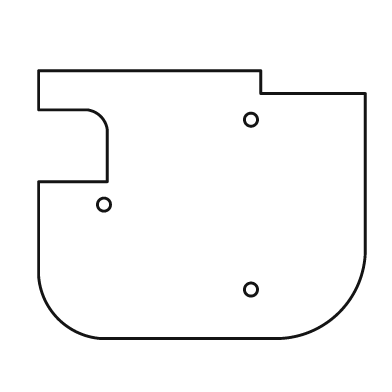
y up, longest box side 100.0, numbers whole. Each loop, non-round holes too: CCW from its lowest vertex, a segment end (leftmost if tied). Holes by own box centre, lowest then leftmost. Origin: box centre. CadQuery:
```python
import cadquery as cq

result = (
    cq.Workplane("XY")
    .moveTo(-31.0, -41.0)
    .lineTo(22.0, -41.0)
    .threePointArc((42.0, -33.0), (50.0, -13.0))
    .lineTo(50.0, 34.0)
    .lineTo(18.0, 34.0)
    .lineTo(18.0, 41.0)
    .lineTo(-50.0, 41.0)
    .lineTo(-50.0, 29.0)
    .lineTo(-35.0, 29.0)
    .threePointArc((-31.0, 27.0), (-29.0, 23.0))
    .lineTo(-29.0, 7.0)
    .lineTo(-50.0, 7.0)
    .lineTo(-50.0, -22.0)
    .threePointArc((-44.0, -35.0), (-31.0, -41.0))
    .close()
    .moveTo(15.0, -26.0)
    .circle(2.0)
    .moveTo(-30.0, 0.0)
    .circle(2.0)
    .moveTo(15.0, 26.0)
    .circle(2.0)
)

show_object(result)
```